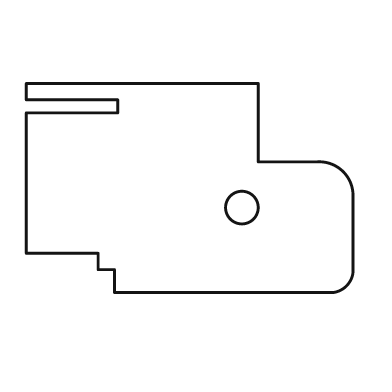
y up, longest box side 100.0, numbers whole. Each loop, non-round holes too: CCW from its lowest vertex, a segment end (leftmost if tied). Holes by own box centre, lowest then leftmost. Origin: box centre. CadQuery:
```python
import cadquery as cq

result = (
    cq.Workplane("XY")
    .moveTo(-23.0, -32.0)
    .lineTo(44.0, -32.0)
    .threePointArc((48.0, -30.0), (50.0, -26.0))
    .lineTo(50.0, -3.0)
    .threePointArc((47.0, 5.0), (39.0, 8.0))
    .lineTo(21.0, 8.0)
    .lineTo(21.0, 32.0)
    .lineTo(-50.0, 32.0)
    .lineTo(-50.0, 27.0)
    .lineTo(-22.0, 27.0)
    .lineTo(-22.0, 23.0)
    .lineTo(-50.0, 23.0)
    .lineTo(-50.0, -20.0)
    .lineTo(-28.0, -20.0)
    .lineTo(-28.0, -25.0)
    .lineTo(-23.0, -25.0)
    .close()
    .moveTo(16.0, -6.0)
    .circle(5.0)
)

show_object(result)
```